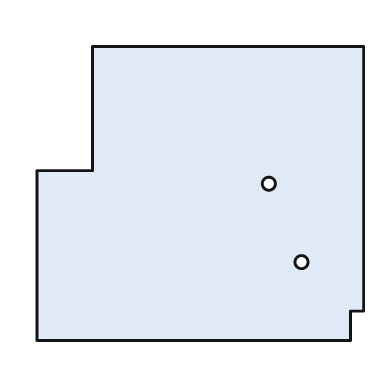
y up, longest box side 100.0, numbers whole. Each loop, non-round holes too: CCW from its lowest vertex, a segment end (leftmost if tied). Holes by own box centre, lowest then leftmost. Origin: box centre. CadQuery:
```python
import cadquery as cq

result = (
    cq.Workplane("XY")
    .moveTo(-50.0, -45.0)
    .lineTo(46.0, -45.0)
    .lineTo(46.0, -36.0)
    .lineTo(50.0, -36.0)
    .lineTo(50.0, 45.0)
    .lineTo(-33.0, 45.0)
    .lineTo(-33.0, 7.0)
    .lineTo(-50.0, 7.0)
    .close()
    .moveTo(31.0, -21.0)
    .circle(2.0)
    .moveTo(21.0, 3.0)
    .circle(2.0)
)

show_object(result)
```